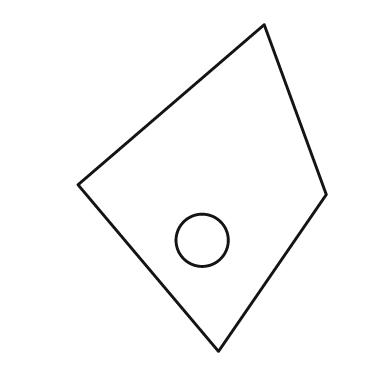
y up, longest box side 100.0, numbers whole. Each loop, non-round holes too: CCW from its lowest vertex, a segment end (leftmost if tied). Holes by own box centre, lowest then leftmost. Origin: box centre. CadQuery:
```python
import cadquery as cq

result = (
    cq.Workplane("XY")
    .moveTo(5.0, -50.0)
    .lineTo(38.0, -2.0)
    .lineTo(19.0, 50.0)
    .lineTo(-38.0, 1.0)
    .close()
    .moveTo(0.0, -16.0)
    .circle(8.0)
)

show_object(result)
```